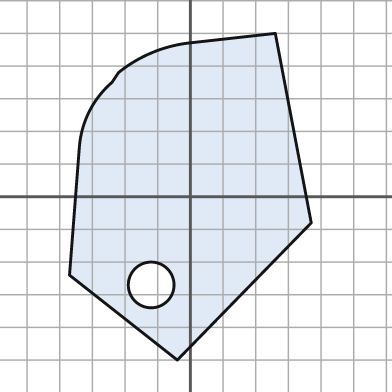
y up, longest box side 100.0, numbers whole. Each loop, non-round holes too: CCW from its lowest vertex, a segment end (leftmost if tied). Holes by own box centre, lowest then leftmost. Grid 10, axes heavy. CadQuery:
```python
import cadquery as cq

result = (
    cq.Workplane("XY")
    .moveTo(-4.0, -50.0)
    .lineTo(37.0, -8.0)
    .lineTo(26.0, 50.0)
    .lineTo(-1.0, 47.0)
    .threePointArc((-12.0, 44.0), (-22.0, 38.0))
    .lineTo(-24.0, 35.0)
    .threePointArc((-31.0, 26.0), (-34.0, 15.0))
    .lineTo(-37.0, -24.0)
    .close()
    .moveTo(-12.0, -27.0)
    .circle(7.0)
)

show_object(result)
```